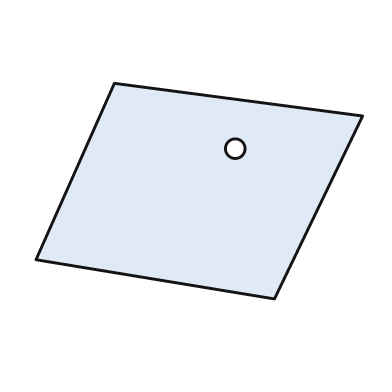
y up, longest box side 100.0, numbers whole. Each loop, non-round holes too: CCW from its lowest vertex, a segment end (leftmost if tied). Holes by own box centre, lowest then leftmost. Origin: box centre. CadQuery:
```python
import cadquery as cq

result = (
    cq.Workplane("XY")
    .moveTo(23.0, -33.0)
    .lineTo(50.0, 23.0)
    .lineTo(-26.0, 33.0)
    .lineTo(-50.0, -21.0)
    .close()
    .moveTo(11.0, 13.0)
    .circle(3.0)
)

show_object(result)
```